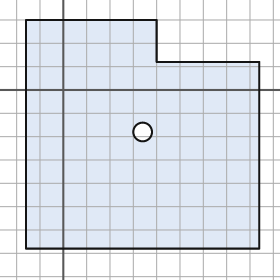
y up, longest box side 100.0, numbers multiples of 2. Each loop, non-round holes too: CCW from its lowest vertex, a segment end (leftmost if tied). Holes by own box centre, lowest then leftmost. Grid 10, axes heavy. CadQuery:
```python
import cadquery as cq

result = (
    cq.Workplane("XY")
    .moveTo(-16.0, -68.0)
    .lineTo(84.0, -68.0)
    .lineTo(84.0, 12.0)
    .lineTo(40.0, 12.0)
    .lineTo(40.0, 30.0)
    .lineTo(-16.0, 30.0)
    .close()
    .moveTo(34.0, -18.0)
    .circle(4.0)
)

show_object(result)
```